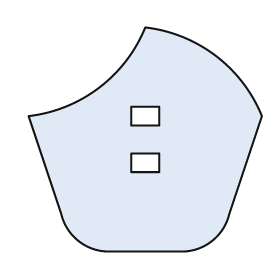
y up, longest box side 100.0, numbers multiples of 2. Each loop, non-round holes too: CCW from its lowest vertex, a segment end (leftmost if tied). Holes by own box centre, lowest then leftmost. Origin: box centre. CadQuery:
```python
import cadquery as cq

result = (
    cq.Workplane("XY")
    .moveTo(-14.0, -48.0)
    .lineTo(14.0, -48.0)
    .threePointArc((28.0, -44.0), (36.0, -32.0))
    .lineTo(50.0, 10.0)
    .threePointArc((30.0, 36.0), (0.0, 48.0))
    .threePointArc((-20.0, 22.0), (-50.0, 10.0))
    .lineTo(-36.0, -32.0)
    .threePointArc((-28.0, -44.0), (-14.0, -48.0))
    .close()
    .moveTo(-6.0, -14.0)
    .lineTo(6.0, -14.0)
    .lineTo(6.0, -6.0)
    .lineTo(-6.0, -6.0)
    .close()
    .moveTo(-6.0, 6.0)
    .lineTo(6.0, 6.0)
    .lineTo(6.0, 14.0)
    .lineTo(-6.0, 14.0)
    .close()
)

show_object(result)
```